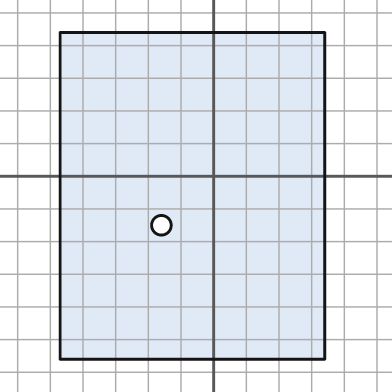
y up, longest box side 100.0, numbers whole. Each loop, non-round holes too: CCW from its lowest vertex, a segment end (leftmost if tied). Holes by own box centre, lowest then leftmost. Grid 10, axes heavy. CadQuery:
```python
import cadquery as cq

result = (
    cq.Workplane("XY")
    .moveTo(-47.0, -56.0)
    .lineTo(34.0, -56.0)
    .lineTo(34.0, 44.0)
    .lineTo(-47.0, 44.0)
    .close()
    .moveTo(-16.0, -15.0)
    .circle(3.0)
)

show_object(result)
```